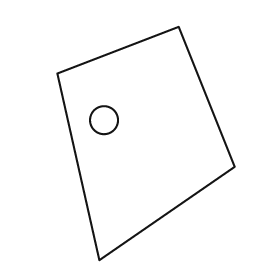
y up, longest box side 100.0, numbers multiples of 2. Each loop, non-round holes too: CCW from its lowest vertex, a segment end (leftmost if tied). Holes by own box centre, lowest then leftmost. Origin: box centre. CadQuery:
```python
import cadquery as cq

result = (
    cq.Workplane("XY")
    .moveTo(-20.0, -50.0)
    .lineTo(38.0, -10.0)
    .lineTo(14.0, 50.0)
    .lineTo(-38.0, 30.0)
    .close()
    .moveTo(-18.0, 10.0)
    .circle(6.0)
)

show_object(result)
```